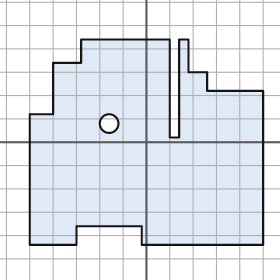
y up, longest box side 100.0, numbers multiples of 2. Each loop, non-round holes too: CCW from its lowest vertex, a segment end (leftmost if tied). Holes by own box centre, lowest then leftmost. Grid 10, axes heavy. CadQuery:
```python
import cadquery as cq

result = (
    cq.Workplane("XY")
    .moveTo(-50.0, -44.0)
    .lineTo(-30.0, -44.0)
    .lineTo(-30.0, -36.0)
    .lineTo(-2.0, -36.0)
    .lineTo(-2.0, -44.0)
    .lineTo(50.0, -44.0)
    .lineTo(50.0, 22.0)
    .lineTo(26.0, 22.0)
    .lineTo(26.0, 30.0)
    .lineTo(18.0, 30.0)
    .lineTo(18.0, 44.0)
    .lineTo(14.0, 44.0)
    .lineTo(14.0, 2.0)
    .lineTo(10.0, 2.0)
    .lineTo(10.0, 44.0)
    .lineTo(-28.0, 44.0)
    .lineTo(-28.0, 34.0)
    .lineTo(-40.0, 34.0)
    .lineTo(-40.0, 12.0)
    .lineTo(-50.0, 12.0)
    .close()
    .moveTo(-16.0, 8.0)
    .circle(4.0)
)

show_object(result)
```